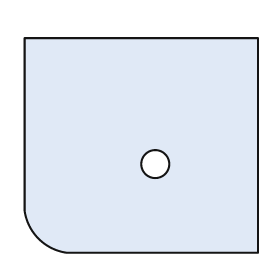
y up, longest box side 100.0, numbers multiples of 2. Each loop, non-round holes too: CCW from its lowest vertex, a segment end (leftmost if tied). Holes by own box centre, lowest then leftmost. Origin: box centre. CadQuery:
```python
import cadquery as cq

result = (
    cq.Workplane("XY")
    .moveTo(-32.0, -46.0)
    .lineTo(50.0, -46.0)
    .lineTo(50.0, 46.0)
    .lineTo(-50.0, 46.0)
    .lineTo(-50.0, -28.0)
    .threePointArc((-44.0, -40.0), (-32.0, -46.0))
    .close()
    .moveTo(6.0, -8.0)
    .circle(6.0)
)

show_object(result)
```